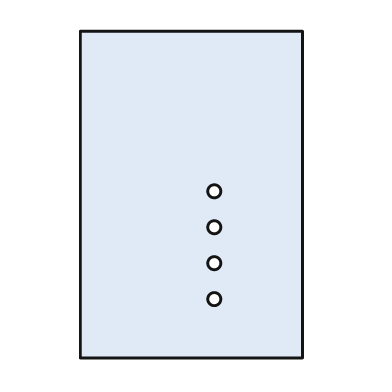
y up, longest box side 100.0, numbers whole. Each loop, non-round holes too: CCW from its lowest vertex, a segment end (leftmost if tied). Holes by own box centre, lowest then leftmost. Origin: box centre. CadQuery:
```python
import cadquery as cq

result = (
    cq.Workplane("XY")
    .moveTo(-34.0, -50.0)
    .lineTo(34.0, -50.0)
    .lineTo(34.0, 50.0)
    .lineTo(-34.0, 50.0)
    .close()
    .moveTo(7.0, -32.0)
    .circle(2.0)
    .moveTo(7.0, -21.0)
    .circle(2.0)
    .moveTo(7.0, -10.0)
    .circle(2.0)
    .moveTo(7.0, 1.0)
    .circle(2.0)
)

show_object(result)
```